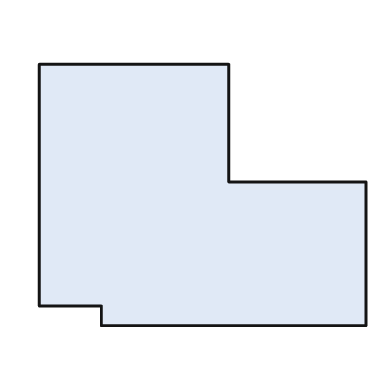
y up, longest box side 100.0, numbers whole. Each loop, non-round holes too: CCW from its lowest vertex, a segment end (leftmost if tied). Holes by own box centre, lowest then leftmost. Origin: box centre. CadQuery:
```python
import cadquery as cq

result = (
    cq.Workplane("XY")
    .moveTo(-31.0, -40.0)
    .lineTo(50.0, -40.0)
    .lineTo(50.0, 4.0)
    .lineTo(8.0, 4.0)
    .lineTo(8.0, 40.0)
    .lineTo(-50.0, 40.0)
    .lineTo(-50.0, -34.0)
    .lineTo(-31.0, -34.0)
    .close()
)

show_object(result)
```